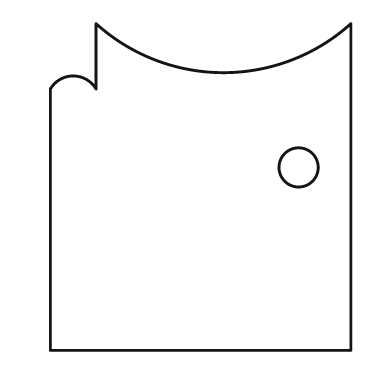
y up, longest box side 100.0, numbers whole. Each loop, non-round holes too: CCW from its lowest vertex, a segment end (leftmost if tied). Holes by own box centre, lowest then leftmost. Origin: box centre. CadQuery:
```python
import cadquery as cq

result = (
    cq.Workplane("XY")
    .moveTo(-46.0, -50.0)
    .lineTo(46.0, -50.0)
    .lineTo(46.0, 50.0)
    .threePointArc((7.0, 35.0), (-32.0, 50.0))
    .lineTo(-32.0, 30.0)
    .threePointArc((-39.0, 34.0), (-46.0, 30.0))
    .close()
    .moveTo(30.0, 6.0)
    .circle(6.0)
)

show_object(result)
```